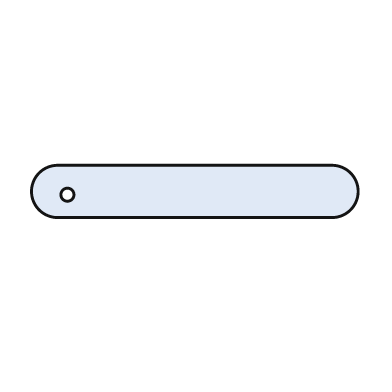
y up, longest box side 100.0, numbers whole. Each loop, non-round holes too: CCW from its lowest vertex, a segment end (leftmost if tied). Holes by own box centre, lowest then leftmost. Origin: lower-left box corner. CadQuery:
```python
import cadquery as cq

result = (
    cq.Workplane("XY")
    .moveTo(8.0, 0.0)
    .lineTo(92.0, 0.0)
    .threePointArc((100.0, 8.0), (92.0, 16.0))
    .lineTo(8.0, 16.0)
    .threePointArc((0.0, 8.0), (8.0, 0.0))
    .close()
    .moveTo(11.0, 7.0)
    .circle(2.0)
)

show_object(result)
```